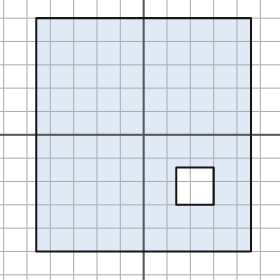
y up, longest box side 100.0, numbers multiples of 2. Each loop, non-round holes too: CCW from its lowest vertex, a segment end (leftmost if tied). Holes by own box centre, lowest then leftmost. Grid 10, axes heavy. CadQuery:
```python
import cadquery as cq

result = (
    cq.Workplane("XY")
    .moveTo(-46.0, -50.0)
    .lineTo(46.0, -50.0)
    .lineTo(46.0, 50.0)
    .lineTo(-46.0, 50.0)
    .close()
    .moveTo(14.0, -30.0)
    .lineTo(30.0, -30.0)
    .lineTo(30.0, -14.0)
    .lineTo(14.0, -14.0)
    .close()
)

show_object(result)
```